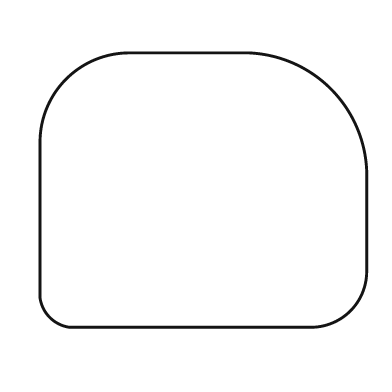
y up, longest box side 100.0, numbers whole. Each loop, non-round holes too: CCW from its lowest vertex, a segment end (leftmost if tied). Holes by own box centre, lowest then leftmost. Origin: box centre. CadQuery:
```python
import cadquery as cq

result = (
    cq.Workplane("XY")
    .moveTo(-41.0, -42.0)
    .lineTo(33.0, -42.0)
    .threePointArc((45.0, -37.0), (50.0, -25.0))
    .lineTo(50.0, 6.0)
    .threePointArc((39.0, 31.0), (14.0, 42.0))
    .lineTo(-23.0, 42.0)
    .threePointArc((-42.0, 34.0), (-50.0, 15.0))
    .lineTo(-50.0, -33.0)
    .threePointArc((-47.0, -39.0), (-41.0, -42.0))
    .close()
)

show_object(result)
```